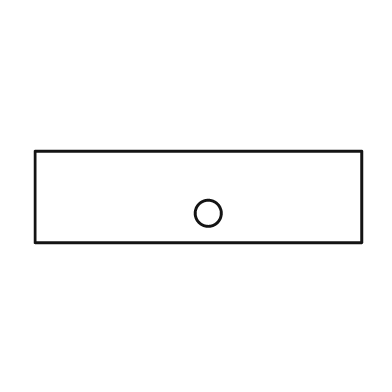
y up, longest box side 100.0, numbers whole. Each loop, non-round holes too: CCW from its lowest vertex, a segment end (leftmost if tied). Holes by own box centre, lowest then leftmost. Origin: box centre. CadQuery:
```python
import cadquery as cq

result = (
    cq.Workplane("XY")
    .moveTo(-50.0, -14.0)
    .lineTo(50.0, -14.0)
    .lineTo(50.0, 14.0)
    .lineTo(-50.0, 14.0)
    .close()
    .moveTo(3.0, -5.0)
    .circle(4.0)
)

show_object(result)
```